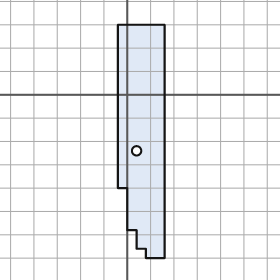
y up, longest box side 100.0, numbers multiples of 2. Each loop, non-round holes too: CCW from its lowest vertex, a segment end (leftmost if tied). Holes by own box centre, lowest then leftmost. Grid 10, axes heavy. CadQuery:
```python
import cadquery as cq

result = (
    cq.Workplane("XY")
    .moveTo(8.0, -70.0)
    .lineTo(16.0, -70.0)
    .lineTo(16.0, 30.0)
    .lineTo(-4.0, 30.0)
    .lineTo(-4.0, -40.0)
    .lineTo(0.0, -40.0)
    .lineTo(0.0, -58.0)
    .lineTo(4.0, -58.0)
    .lineTo(4.0, -66.0)
    .lineTo(8.0, -66.0)
    .close()
    .moveTo(4.0, -24.0)
    .circle(2.0)
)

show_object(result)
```